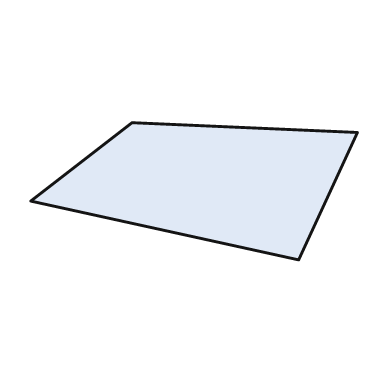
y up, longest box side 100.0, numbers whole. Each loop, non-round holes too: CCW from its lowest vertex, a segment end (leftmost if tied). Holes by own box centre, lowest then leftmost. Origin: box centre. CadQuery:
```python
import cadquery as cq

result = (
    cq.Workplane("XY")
    .moveTo(32.0, -21.0)
    .lineTo(50.0, 18.0)
    .lineTo(-19.0, 21.0)
    .lineTo(-50.0, -3.0)
    .close()
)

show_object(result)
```